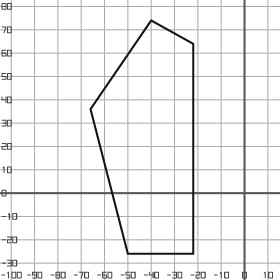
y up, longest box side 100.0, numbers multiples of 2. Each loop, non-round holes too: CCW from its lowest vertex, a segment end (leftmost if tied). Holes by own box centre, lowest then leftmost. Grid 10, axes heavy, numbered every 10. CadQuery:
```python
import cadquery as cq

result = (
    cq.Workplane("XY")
    .moveTo(-50.0, -26.0)
    .lineTo(-22.0, -26.0)
    .lineTo(-22.0, 64.0)
    .lineTo(-40.0, 74.0)
    .lineTo(-66.0, 36.0)
    .close()
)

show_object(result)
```